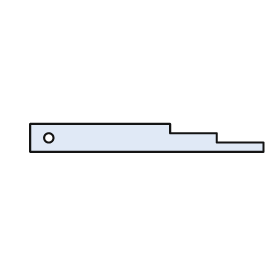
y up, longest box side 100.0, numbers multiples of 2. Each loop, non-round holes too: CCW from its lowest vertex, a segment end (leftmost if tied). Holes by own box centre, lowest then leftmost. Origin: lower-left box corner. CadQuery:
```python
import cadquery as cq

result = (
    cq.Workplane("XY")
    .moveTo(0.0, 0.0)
    .lineTo(100.0, 0.0)
    .lineTo(100.0, 4.0)
    .lineTo(80.0, 4.0)
    .lineTo(80.0, 8.0)
    .lineTo(60.0, 8.0)
    .lineTo(60.0, 12.0)
    .lineTo(0.0, 12.0)
    .close()
    .moveTo(8.0, 6.0)
    .circle(2.0)
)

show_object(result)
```